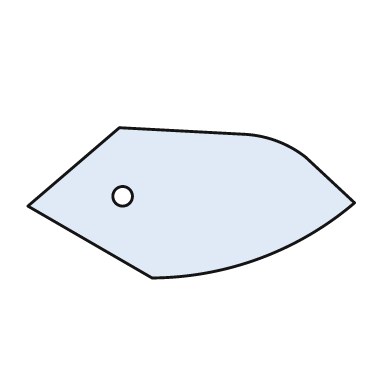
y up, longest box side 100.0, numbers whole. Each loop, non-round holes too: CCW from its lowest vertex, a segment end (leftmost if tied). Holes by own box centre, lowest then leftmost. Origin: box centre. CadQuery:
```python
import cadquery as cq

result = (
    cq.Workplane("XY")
    .moveTo(-12.0, -23.0)
    .threePointArc((21.0, -17.0), (50.0, 0.0))
    .lineTo(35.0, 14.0)
    .threePointArc((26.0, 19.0), (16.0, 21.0))
    .lineTo(-22.0, 23.0)
    .lineTo(-50.0, -1.0)
    .close()
    .moveTo(-21.0, 2.0)
    .circle(3.0)
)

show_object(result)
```